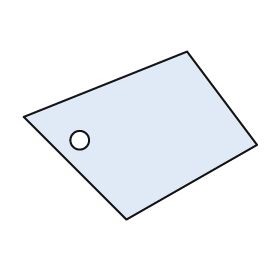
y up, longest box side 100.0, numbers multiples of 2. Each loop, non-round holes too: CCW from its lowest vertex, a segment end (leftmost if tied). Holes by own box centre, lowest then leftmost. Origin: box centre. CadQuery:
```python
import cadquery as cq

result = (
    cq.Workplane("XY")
    .moveTo(-6.0, -36.0)
    .lineTo(50.0, -4.0)
    .lineTo(20.0, 36.0)
    .lineTo(-50.0, 8.0)
    .close()
    .moveTo(-26.0, -2.0)
    .circle(4.0)
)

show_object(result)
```